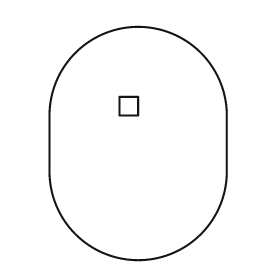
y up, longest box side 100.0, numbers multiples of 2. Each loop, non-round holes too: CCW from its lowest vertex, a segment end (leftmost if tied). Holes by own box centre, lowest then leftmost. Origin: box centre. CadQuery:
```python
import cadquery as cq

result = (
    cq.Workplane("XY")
    .moveTo(-38.0, -12.0)
    .threePointArc((0.0, -50.0), (38.0, -12.0))
    .lineTo(38.0, 12.0)
    .threePointArc((0.0, 50.0), (-38.0, 12.0))
    .close()
    .moveTo(-8.0, 12.0)
    .lineTo(0.0, 12.0)
    .lineTo(0.0, 20.0)
    .lineTo(-8.0, 20.0)
    .close()
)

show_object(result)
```